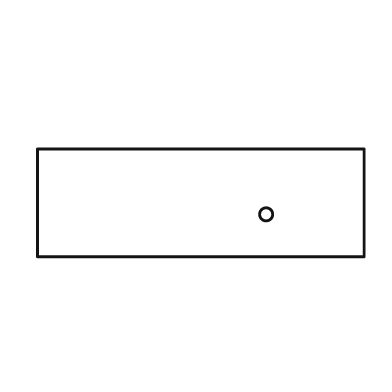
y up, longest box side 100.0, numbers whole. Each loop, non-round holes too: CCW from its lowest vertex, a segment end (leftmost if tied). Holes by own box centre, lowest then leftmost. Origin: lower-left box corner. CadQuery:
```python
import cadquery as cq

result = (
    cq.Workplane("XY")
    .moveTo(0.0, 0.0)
    .lineTo(100.0, 0.0)
    .lineTo(100.0, 33.0)
    .lineTo(0.0, 33.0)
    .close()
    .moveTo(70.0, 13.0)
    .circle(2.0)
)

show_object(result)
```